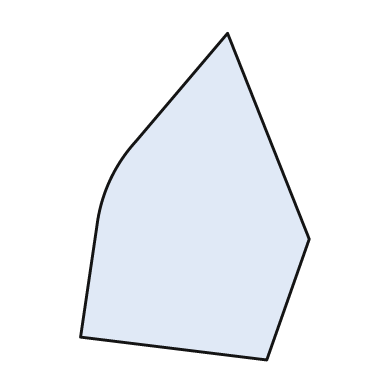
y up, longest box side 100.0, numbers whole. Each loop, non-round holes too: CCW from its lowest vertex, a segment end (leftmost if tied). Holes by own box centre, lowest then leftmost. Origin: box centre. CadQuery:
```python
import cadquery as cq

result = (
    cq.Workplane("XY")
    .moveTo(22.0, -50.0)
    .lineTo(35.0, -13.0)
    .lineTo(10.0, 50.0)
    .lineTo(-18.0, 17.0)
    .threePointArc((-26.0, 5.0), (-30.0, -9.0))
    .lineTo(-35.0, -43.0)
    .close()
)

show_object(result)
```